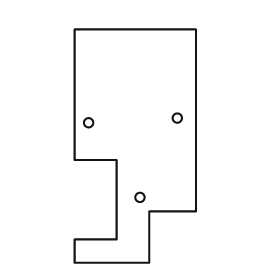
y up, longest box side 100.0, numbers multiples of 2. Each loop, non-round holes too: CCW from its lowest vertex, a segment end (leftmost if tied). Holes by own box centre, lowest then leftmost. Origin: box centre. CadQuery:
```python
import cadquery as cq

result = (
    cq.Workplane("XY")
    .moveTo(-26.0, -50.0)
    .lineTo(6.0, -50.0)
    .lineTo(6.0, -28.0)
    .lineTo(26.0, -28.0)
    .lineTo(26.0, 50.0)
    .lineTo(-26.0, 50.0)
    .lineTo(-26.0, -6.0)
    .lineTo(-8.0, -6.0)
    .lineTo(-8.0, -40.0)
    .lineTo(-26.0, -40.0)
    .close()
    .moveTo(2.0, -22.0)
    .circle(2.0)
    .moveTo(-20.0, 10.0)
    .circle(2.0)
    .moveTo(18.0, 12.0)
    .circle(2.0)
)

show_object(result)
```